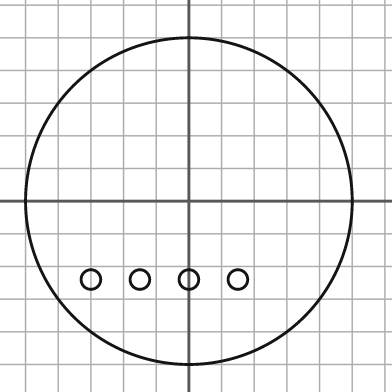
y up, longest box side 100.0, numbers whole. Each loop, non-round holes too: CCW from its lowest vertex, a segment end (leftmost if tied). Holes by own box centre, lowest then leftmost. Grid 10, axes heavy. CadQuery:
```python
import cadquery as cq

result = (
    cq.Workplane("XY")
    .moveTo(0.0, 0.0)
    .circle(50.0)
    .moveTo(-30.0, -24.0)
    .circle(3.0)
    .moveTo(-15.0, -24.0)
    .circle(3.0)
    .moveTo(0.0, -24.0)
    .circle(3.0)
    .moveTo(15.0, -24.0)
    .circle(3.0)
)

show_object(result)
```